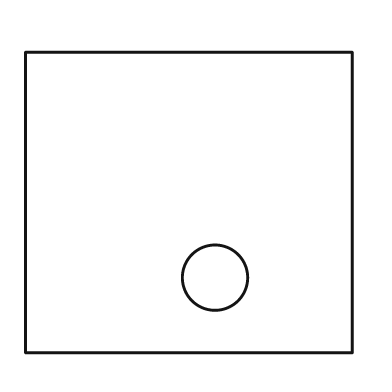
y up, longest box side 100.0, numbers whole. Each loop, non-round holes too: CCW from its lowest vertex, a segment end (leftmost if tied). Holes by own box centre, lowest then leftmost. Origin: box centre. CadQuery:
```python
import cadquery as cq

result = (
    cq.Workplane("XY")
    .moveTo(-50.0, -46.0)
    .lineTo(50.0, -46.0)
    .lineTo(50.0, 46.0)
    .lineTo(-50.0, 46.0)
    .close()
    .moveTo(8.0, -23.0)
    .circle(10.0)
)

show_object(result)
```